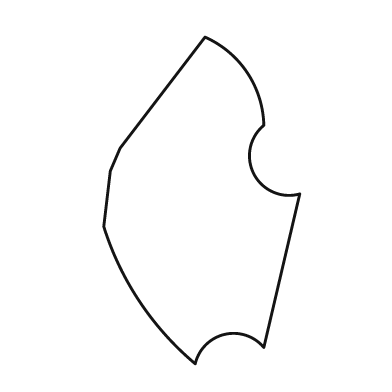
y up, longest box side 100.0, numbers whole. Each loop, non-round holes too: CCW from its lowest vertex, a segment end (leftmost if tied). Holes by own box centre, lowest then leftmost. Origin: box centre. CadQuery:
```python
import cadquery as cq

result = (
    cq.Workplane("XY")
    .moveTo(-2.0, -50.0)
    .threePointArc((7.0, -41.0), (19.0, -45.0))
    .lineTo(30.0, 2.0)
    .threePointArc((16.0, 8.0), (19.0, 23.0))
    .threePointArc((14.0, 39.0), (1.0, 50.0))
    .lineTo(-25.0, 16.0)
    .lineTo(-28.0, 9.0)
    .lineTo(-30.0, -8.0)
    .threePointArc((-19.0, -31.0), (-2.0, -50.0))
    .close()
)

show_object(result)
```